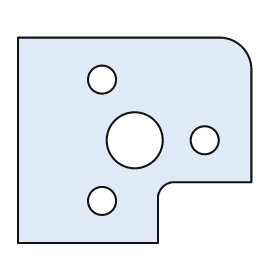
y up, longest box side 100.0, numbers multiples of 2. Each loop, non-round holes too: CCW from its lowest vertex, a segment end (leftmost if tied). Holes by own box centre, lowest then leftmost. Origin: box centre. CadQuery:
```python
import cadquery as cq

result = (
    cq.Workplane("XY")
    .moveTo(-50.0, -44.0)
    .lineTo(10.0, -44.0)
    .lineTo(10.0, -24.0)
    .threePointArc((12.0, -20.0), (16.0, -18.0))
    .lineTo(50.0, -18.0)
    .lineTo(50.0, 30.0)
    .threePointArc((46.0, 40.0), (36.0, 44.0))
    .lineTo(-50.0, 44.0)
    .close()
    .moveTo(-14.0, -26.0)
    .circle(6.0)
    .moveTo(0.0, 0.0)
    .circle(12.0)
    .moveTo(30.0, 0.0)
    .circle(6.0)
    .moveTo(-14.0, 26.0)
    .circle(6.0)
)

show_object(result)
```